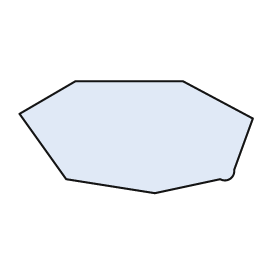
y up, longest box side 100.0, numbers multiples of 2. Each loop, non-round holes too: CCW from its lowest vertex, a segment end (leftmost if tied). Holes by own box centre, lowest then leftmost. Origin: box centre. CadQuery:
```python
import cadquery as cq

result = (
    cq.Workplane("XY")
    .moveTo(8.0, -24.0)
    .lineTo(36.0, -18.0)
    .threePointArc((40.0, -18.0), (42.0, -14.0))
    .lineTo(50.0, 8.0)
    .lineTo(20.0, 24.0)
    .lineTo(-26.0, 24.0)
    .lineTo(-50.0, 10.0)
    .lineTo(-30.0, -18.0)
    .close()
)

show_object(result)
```